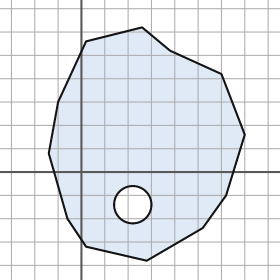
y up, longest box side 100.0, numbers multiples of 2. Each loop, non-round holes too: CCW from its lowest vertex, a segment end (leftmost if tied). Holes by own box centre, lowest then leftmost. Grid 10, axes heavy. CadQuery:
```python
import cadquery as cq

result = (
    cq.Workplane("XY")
    .moveTo(28.0, -38.0)
    .lineTo(52.0, -24.0)
    .lineTo(62.0, -10.0)
    .lineTo(70.0, 16.0)
    .lineTo(60.0, 42.0)
    .lineTo(38.0, 52.0)
    .lineTo(26.0, 62.0)
    .lineTo(2.0, 56.0)
    .lineTo(-10.0, 30.0)
    .lineTo(-14.0, 8.0)
    .lineTo(-6.0, -20.0)
    .lineTo(2.0, -32.0)
    .close()
    .moveTo(22.0, -14.0)
    .circle(8.0)
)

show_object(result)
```